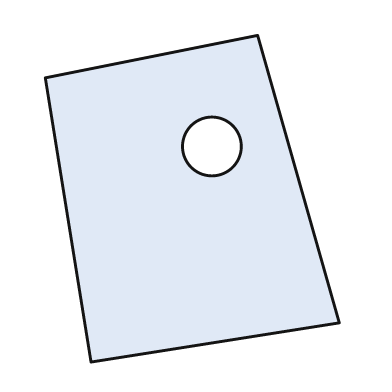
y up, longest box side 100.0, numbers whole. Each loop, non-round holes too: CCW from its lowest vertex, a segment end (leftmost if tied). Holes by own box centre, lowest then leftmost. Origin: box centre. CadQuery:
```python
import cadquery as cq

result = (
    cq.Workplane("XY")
    .moveTo(-31.0, -50.0)
    .lineTo(45.0, -38.0)
    .lineTo(20.0, 50.0)
    .lineTo(-45.0, 37.0)
    .close()
    .moveTo(6.0, 16.0)
    .circle(9.0)
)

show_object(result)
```